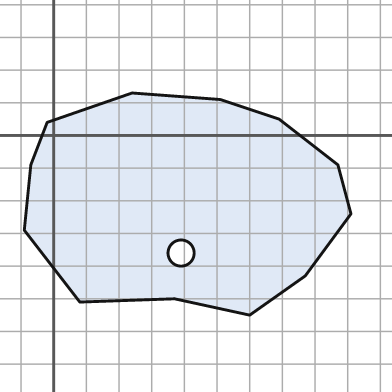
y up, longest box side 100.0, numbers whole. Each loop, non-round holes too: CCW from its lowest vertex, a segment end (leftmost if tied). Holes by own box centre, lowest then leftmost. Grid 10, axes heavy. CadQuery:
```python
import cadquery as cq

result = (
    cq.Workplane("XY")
    .moveTo(60.0, -55.0)
    .lineTo(77.0, -43.0)
    .lineTo(91.0, -24.0)
    .lineTo(87.0, -9.0)
    .lineTo(69.0, 5.0)
    .lineTo(51.0, 11.0)
    .lineTo(24.0, 13.0)
    .lineTo(-2.0, 4.0)
    .lineTo(-7.0, -9.0)
    .lineTo(-9.0, -29.0)
    .lineTo(8.0, -51.0)
    .lineTo(37.0, -50.0)
    .close()
    .moveTo(39.0, -36.0)
    .circle(4.0)
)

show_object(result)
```